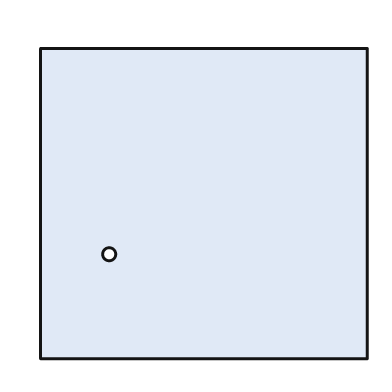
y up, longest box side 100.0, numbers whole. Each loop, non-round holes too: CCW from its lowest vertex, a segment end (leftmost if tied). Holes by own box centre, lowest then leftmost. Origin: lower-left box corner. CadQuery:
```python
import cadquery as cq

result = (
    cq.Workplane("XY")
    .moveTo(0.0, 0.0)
    .lineTo(100.0, 0.0)
    .lineTo(100.0, 95.0)
    .lineTo(0.0, 95.0)
    .close()
    .moveTo(21.0, 32.0)
    .circle(2.0)
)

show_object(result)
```